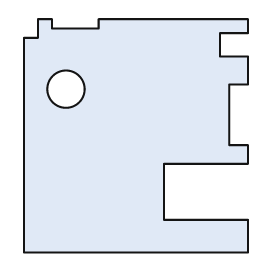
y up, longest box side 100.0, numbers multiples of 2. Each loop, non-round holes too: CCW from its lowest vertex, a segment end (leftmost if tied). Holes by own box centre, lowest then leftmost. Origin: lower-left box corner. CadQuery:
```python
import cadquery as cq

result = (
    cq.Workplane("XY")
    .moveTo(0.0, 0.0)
    .lineTo(96.0, 0.0)
    .lineTo(96.0, 14.0)
    .lineTo(60.0, 14.0)
    .lineTo(60.0, 38.0)
    .lineTo(96.0, 38.0)
    .lineTo(96.0, 46.0)
    .lineTo(88.0, 46.0)
    .lineTo(88.0, 72.0)
    .lineTo(96.0, 72.0)
    .lineTo(96.0, 84.0)
    .lineTo(84.0, 84.0)
    .lineTo(84.0, 94.0)
    .lineTo(96.0, 94.0)
    .lineTo(96.0, 100.0)
    .lineTo(32.0, 100.0)
    .lineTo(32.0, 96.0)
    .lineTo(12.0, 96.0)
    .lineTo(12.0, 100.0)
    .lineTo(6.0, 100.0)
    .lineTo(6.0, 92.0)
    .lineTo(0.0, 92.0)
    .close()
    .moveTo(18.0, 70.0)
    .circle(8.0)
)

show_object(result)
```